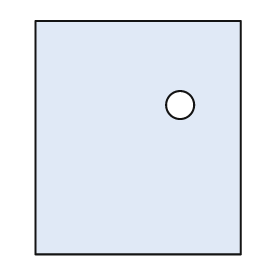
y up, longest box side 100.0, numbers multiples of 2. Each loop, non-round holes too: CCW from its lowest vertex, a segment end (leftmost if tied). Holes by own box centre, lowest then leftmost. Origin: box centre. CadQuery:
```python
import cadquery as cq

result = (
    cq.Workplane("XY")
    .moveTo(-44.0, -50.0)
    .lineTo(44.0, -50.0)
    .lineTo(44.0, 50.0)
    .lineTo(-44.0, 50.0)
    .close()
    .moveTo(18.0, 14.0)
    .circle(6.0)
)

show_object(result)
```